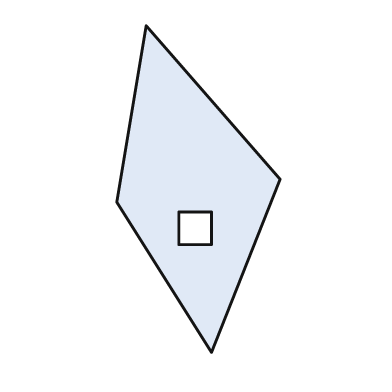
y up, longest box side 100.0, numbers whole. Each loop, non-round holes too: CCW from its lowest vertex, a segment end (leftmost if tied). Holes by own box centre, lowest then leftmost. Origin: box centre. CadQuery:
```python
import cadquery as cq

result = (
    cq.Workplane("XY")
    .moveTo(4.0, -50.0)
    .lineTo(25.0, 3.0)
    .lineTo(-16.0, 50.0)
    .lineTo(-25.0, -4.0)
    .close()
    .moveTo(-6.0, -17.0)
    .lineTo(4.0, -17.0)
    .lineTo(4.0, -7.0)
    .lineTo(-6.0, -7.0)
    .close()
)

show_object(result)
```